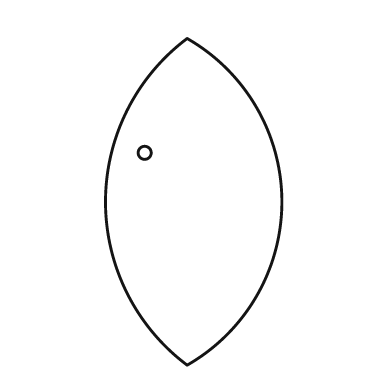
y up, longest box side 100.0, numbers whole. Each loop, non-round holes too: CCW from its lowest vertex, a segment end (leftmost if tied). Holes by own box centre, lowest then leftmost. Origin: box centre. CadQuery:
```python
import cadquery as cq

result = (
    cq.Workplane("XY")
    .moveTo(-2.0, -50.0)
    .threePointArc((27.0, 0.0), (-2.0, 50.0))
    .threePointArc((-27.0, 0.0), (-2.0, -50.0))
    .close()
    .moveTo(-15.0, 15.0)
    .circle(2.0)
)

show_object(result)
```